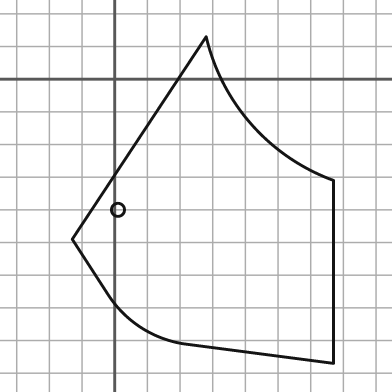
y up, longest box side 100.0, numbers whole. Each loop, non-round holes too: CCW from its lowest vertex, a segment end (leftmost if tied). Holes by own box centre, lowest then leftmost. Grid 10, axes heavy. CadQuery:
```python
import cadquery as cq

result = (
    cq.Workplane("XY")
    .moveTo(67.0, -87.0)
    .lineTo(67.0, -31.0)
    .threePointArc((42.0, -14.0), (28.0, 13.0))
    .lineTo(-13.0, -49.0)
    .lineTo(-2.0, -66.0)
    .threePointArc((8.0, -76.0), (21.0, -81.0))
    .close()
    .moveTo(1.0, -40.0)
    .circle(2.0)
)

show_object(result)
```